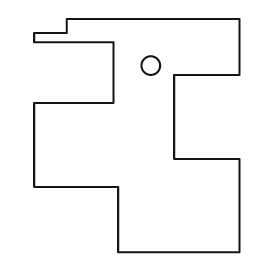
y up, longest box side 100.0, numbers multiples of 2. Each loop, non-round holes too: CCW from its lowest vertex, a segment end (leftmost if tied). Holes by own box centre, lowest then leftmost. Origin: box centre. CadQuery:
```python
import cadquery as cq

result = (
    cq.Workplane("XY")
    .moveTo(-8.0, -50.0)
    .lineTo(44.0, -50.0)
    .lineTo(44.0, -10.0)
    .lineTo(16.0, -10.0)
    .lineTo(16.0, 26.0)
    .lineTo(44.0, 26.0)
    .lineTo(44.0, 50.0)
    .lineTo(-30.0, 50.0)
    .lineTo(-30.0, 44.0)
    .lineTo(-44.0, 44.0)
    .lineTo(-44.0, 40.0)
    .lineTo(-10.0, 40.0)
    .lineTo(-10.0, 14.0)
    .lineTo(-44.0, 14.0)
    .lineTo(-44.0, -22.0)
    .lineTo(-8.0, -22.0)
    .close()
    .moveTo(6.0, 30.0)
    .circle(4.0)
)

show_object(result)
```